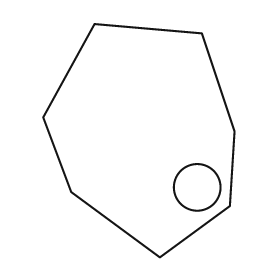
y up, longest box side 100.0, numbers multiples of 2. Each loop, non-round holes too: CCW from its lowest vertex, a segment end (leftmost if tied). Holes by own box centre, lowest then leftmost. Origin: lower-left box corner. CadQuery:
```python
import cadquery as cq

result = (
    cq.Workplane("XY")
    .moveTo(50.0, 0.0)
    .lineTo(80.0, 22.0)
    .lineTo(82.0, 54.0)
    .lineTo(68.0, 96.0)
    .lineTo(22.0, 100.0)
    .lineTo(0.0, 60.0)
    .lineTo(12.0, 28.0)
    .close()
    .moveTo(66.0, 30.0)
    .circle(10.0)
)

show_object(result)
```